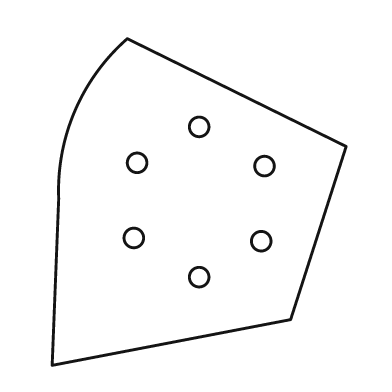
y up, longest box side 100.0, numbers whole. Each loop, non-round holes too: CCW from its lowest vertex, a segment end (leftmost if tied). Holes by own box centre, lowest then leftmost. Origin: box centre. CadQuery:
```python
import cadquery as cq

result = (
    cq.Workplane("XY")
    .moveTo(-45.0, -50.0)
    .lineTo(28.0, -36.0)
    .lineTo(45.0, 17.0)
    .lineTo(-22.0, 50.0)
    .threePointArc((-38.0, 28.0), (-43.0, 1.0))
    .close()
    .moveTo(0.0, -23.0)
    .circle(3.0)
    .moveTo(19.0, -12.0)
    .circle(3.0)
    .moveTo(-20.0, -11.0)
    .circle(3.0)
    .moveTo(20.0, 11.0)
    .circle(3.0)
    .moveTo(-19.0, 12.0)
    .circle(3.0)
    .moveTo(0.0, 23.0)
    .circle(3.0)
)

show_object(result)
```